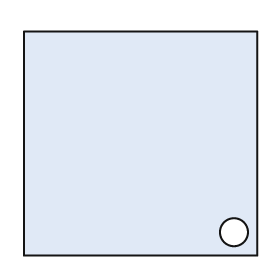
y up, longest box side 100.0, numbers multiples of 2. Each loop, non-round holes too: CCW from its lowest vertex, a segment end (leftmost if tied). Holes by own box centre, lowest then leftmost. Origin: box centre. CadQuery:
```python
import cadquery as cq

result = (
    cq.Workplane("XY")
    .moveTo(-50.0, -48.0)
    .lineTo(50.0, -48.0)
    .lineTo(50.0, 48.0)
    .lineTo(-50.0, 48.0)
    .close()
    .moveTo(40.0, -38.0)
    .circle(6.0)
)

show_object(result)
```